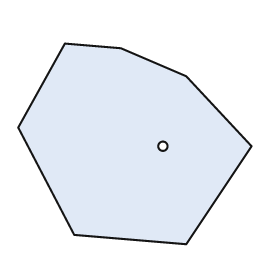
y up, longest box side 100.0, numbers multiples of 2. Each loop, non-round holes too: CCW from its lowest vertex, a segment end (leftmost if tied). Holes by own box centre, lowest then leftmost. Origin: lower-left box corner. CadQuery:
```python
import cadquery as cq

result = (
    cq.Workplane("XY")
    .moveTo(72.0, 0.0)
    .lineTo(100.0, 42.0)
    .lineTo(72.0, 72.0)
    .lineTo(44.0, 84.0)
    .lineTo(20.0, 86.0)
    .lineTo(0.0, 50.0)
    .lineTo(24.0, 4.0)
    .close()
    .moveTo(62.0, 42.0)
    .circle(2.0)
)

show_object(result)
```